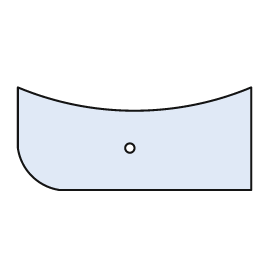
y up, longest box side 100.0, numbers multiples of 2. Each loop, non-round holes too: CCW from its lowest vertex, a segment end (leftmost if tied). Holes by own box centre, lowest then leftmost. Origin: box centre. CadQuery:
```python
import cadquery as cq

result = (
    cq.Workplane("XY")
    .moveTo(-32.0, -22.0)
    .lineTo(50.0, -22.0)
    .lineTo(50.0, 22.0)
    .threePointArc((0.0, 12.0), (-50.0, 22.0))
    .lineTo(-50.0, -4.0)
    .threePointArc((-44.0, -16.0), (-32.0, -22.0))
    .close()
    .moveTo(-2.0, -4.0)
    .circle(2.0)
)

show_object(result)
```